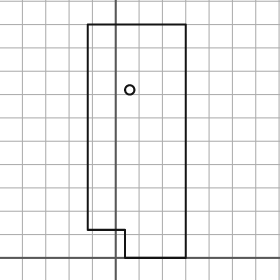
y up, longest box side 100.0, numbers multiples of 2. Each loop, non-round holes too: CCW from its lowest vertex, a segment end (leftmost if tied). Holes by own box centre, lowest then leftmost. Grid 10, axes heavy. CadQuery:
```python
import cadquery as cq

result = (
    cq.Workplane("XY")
    .moveTo(4.0, 0.0)
    .lineTo(30.0, 0.0)
    .lineTo(30.0, 100.0)
    .lineTo(-12.0, 100.0)
    .lineTo(-12.0, 12.0)
    .lineTo(4.0, 12.0)
    .close()
    .moveTo(6.0, 72.0)
    .circle(2.0)
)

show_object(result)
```